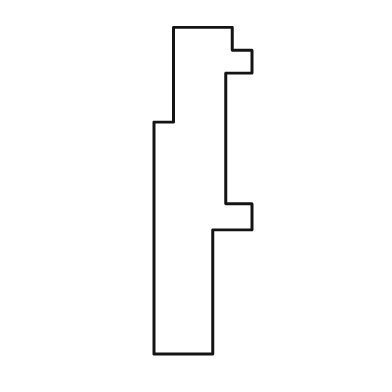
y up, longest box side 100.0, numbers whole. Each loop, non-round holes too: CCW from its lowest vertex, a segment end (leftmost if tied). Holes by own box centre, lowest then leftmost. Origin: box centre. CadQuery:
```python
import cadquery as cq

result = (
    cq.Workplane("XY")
    .moveTo(-15.0, -50.0)
    .lineTo(3.0, -50.0)
    .lineTo(3.0, -12.0)
    .lineTo(15.0, -12.0)
    .lineTo(15.0, -4.0)
    .lineTo(7.0, -4.0)
    .lineTo(7.0, 36.0)
    .lineTo(15.0, 36.0)
    .lineTo(15.0, 43.0)
    .lineTo(9.0, 43.0)
    .lineTo(9.0, 50.0)
    .lineTo(-9.0, 50.0)
    .lineTo(-9.0, 21.0)
    .lineTo(-15.0, 21.0)
    .close()
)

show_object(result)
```